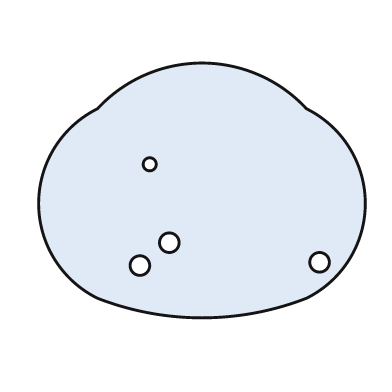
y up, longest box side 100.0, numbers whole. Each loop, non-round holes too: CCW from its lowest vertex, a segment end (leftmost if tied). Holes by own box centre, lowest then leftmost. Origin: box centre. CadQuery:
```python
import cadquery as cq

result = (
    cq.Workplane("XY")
    .moveTo(-32.0, -33.0)
    .threePointArc((0.0, -39.0), (32.0, -33.0))
    .threePointArc((50.0, -4.0), (32.0, 25.0))
    .threePointArc((0.0, 39.0), (-32.0, 25.0))
    .threePointArc((-50.0, -4.0), (-32.0, -33.0))
    .close()
    .moveTo(-19.0, -23.0)
    .circle(3.0)
    .moveTo(36.0, -22.0)
    .circle(3.0)
    .moveTo(-10.0, -16.0)
    .circle(3.0)
    .moveTo(-16.0, 8.0)
    .circle(2.0)
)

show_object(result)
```